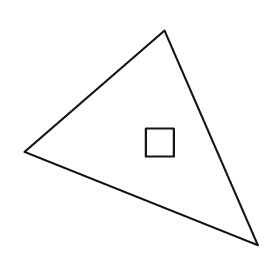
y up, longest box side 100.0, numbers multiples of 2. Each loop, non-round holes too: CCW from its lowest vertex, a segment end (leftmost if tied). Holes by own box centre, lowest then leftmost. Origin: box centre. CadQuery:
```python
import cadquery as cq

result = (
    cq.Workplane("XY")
    .moveTo(50.0, -46.0)
    .lineTo(10.0, 46.0)
    .lineTo(-50.0, -6.0)
    .close()
    .moveTo(2.0, -8.0)
    .lineTo(14.0, -8.0)
    .lineTo(14.0, 4.0)
    .lineTo(2.0, 4.0)
    .close()
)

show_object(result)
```